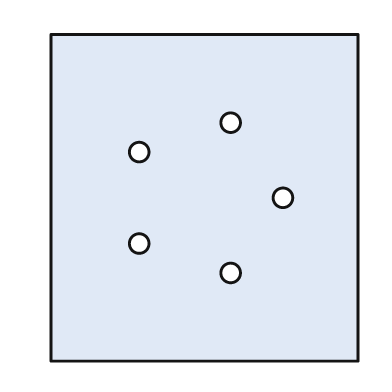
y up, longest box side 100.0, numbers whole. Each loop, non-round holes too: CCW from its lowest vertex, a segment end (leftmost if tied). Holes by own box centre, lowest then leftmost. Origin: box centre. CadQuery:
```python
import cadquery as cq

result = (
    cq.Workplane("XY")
    .moveTo(-47.0, -50.0)
    .lineTo(47.0, -50.0)
    .lineTo(47.0, 50.0)
    .lineTo(-47.0, 50.0)
    .close()
    .moveTo(8.0, -23.0)
    .circle(3.0)
    .moveTo(-20.0, -14.0)
    .circle(3.0)
    .moveTo(24.0, 0.0)
    .circle(3.0)
    .moveTo(-20.0, 14.0)
    .circle(3.0)
    .moveTo(8.0, 23.0)
    .circle(3.0)
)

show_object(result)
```